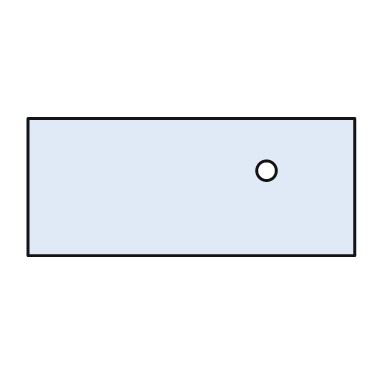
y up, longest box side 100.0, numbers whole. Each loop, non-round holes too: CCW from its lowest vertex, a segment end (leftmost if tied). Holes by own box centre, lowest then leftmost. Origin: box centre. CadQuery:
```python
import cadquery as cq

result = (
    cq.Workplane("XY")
    .moveTo(-50.0, -21.0)
    .lineTo(50.0, -21.0)
    .lineTo(50.0, 21.0)
    .lineTo(-50.0, 21.0)
    .close()
    .moveTo(23.0, 5.0)
    .circle(3.0)
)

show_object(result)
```